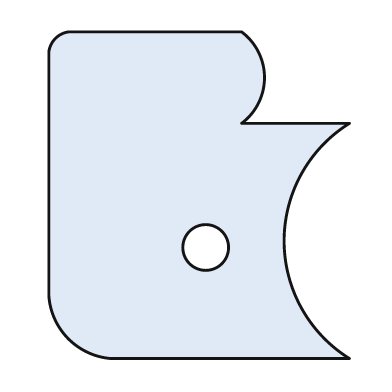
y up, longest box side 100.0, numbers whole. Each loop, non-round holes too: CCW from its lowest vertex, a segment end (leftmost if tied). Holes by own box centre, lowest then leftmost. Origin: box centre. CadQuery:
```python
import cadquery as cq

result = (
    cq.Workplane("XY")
    .moveTo(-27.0, -50.0)
    .lineTo(46.0, -50.0)
    .threePointArc((26.0, -14.0), (46.0, 22.0))
    .lineTo(13.0, 22.0)
    .threePointArc((20.0, 36.0), (13.0, 50.0))
    .lineTo(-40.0, 50.0)
    .threePointArc((-44.0, 48.0), (-46.0, 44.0))
    .lineTo(-46.0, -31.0)
    .threePointArc((-40.0, -44.0), (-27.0, -50.0))
    .close()
    .moveTo(2.0, -16.0)
    .circle(7.0)
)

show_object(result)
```